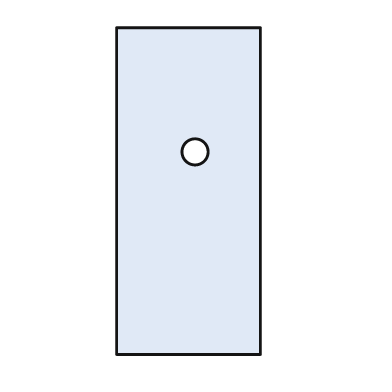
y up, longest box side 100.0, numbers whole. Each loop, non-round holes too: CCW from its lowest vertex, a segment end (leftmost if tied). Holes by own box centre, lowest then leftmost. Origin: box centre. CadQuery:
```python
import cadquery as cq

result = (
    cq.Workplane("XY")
    .moveTo(-22.0, -50.0)
    .lineTo(22.0, -50.0)
    .lineTo(22.0, 50.0)
    .lineTo(-22.0, 50.0)
    .close()
    .moveTo(2.0, 12.0)
    .circle(4.0)
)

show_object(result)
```